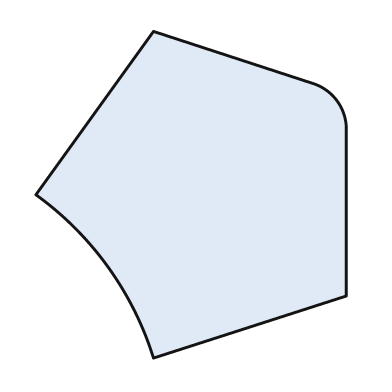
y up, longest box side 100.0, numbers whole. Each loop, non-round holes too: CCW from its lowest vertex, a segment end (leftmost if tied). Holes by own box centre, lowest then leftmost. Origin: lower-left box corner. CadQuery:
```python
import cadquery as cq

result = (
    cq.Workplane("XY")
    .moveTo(36.0, 0.0)
    .lineTo(95.0, 19.0)
    .lineTo(95.0, 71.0)
    .threePointArc((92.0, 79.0), (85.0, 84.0))
    .lineTo(36.0, 100.0)
    .lineTo(0.0, 50.0)
    .threePointArc((22.0, 28.0), (36.0, 0.0))
    .close()
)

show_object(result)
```